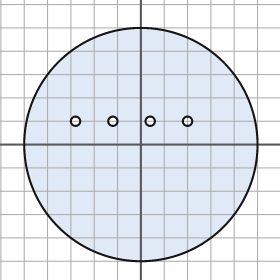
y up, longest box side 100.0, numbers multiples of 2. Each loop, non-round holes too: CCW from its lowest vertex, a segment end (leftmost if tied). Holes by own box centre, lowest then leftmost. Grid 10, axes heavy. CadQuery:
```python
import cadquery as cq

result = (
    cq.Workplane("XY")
    .moveTo(0.0, 0.0)
    .circle(50.0)
    .moveTo(-28.0, 10.0)
    .circle(2.0)
    .moveTo(-12.0, 10.0)
    .circle(2.0)
    .moveTo(4.0, 10.0)
    .circle(2.0)
    .moveTo(20.0, 10.0)
    .circle(2.0)
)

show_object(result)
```